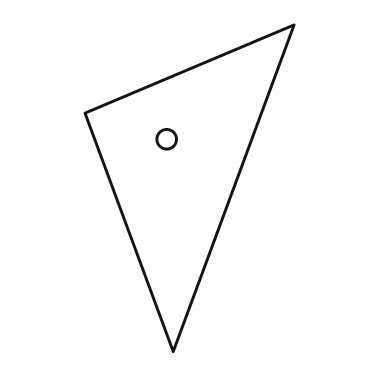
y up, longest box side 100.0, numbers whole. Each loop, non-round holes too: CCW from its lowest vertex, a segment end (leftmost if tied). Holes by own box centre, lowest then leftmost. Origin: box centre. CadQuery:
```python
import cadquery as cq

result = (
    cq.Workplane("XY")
    .moveTo(-5.0, -50.0)
    .lineTo(32.0, 50.0)
    .lineTo(-32.0, 23.0)
    .close()
    .moveTo(-7.0, 15.0)
    .circle(3.0)
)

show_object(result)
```